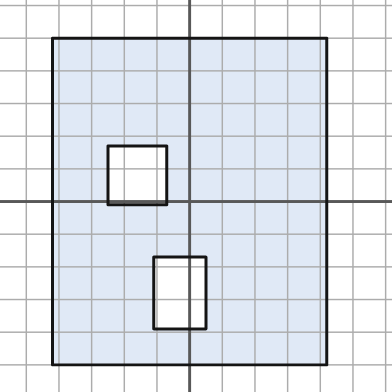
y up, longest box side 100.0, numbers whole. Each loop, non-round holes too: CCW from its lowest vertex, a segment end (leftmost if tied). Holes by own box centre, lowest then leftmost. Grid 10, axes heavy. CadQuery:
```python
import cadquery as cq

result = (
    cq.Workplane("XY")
    .moveTo(-42.0, -50.0)
    .lineTo(42.0, -50.0)
    .lineTo(42.0, 50.0)
    .lineTo(-42.0, 50.0)
    .close()
    .moveTo(-11.0, -39.0)
    .lineTo(5.0, -39.0)
    .lineTo(5.0, -17.0)
    .lineTo(-11.0, -17.0)
    .close()
    .moveTo(-25.0, -1.0)
    .lineTo(-7.0, -1.0)
    .lineTo(-7.0, 17.0)
    .lineTo(-25.0, 17.0)
    .close()
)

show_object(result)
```